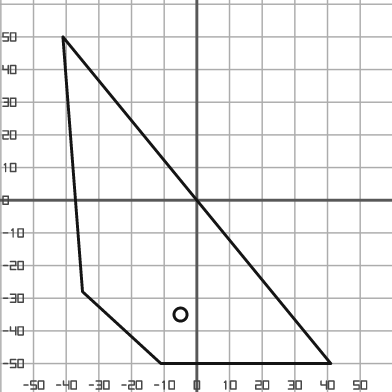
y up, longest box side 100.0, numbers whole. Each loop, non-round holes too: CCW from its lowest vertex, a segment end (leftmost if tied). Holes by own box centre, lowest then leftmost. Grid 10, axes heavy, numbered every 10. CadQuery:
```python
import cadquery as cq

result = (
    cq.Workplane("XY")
    .moveTo(-11.0, -50.0)
    .lineTo(41.0, -50.0)
    .lineTo(-41.0, 50.0)
    .lineTo(-35.0, -28.0)
    .close()
    .moveTo(-5.0, -35.0)
    .circle(2.0)
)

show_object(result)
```